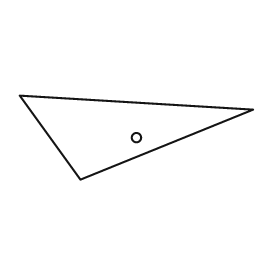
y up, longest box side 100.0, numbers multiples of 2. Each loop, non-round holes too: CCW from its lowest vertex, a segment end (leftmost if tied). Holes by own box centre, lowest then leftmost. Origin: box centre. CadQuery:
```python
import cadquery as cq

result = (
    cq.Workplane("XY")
    .moveTo(-24.0, -18.0)
    .lineTo(50.0, 12.0)
    .lineTo(-50.0, 18.0)
    .close()
    .moveTo(0.0, 0.0)
    .circle(2.0)
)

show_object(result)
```